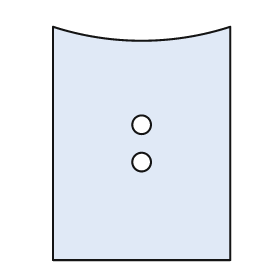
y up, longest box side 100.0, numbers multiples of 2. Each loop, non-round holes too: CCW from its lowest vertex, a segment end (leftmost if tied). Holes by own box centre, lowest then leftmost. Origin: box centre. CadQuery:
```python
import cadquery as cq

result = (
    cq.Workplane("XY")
    .moveTo(-38.0, -50.0)
    .lineTo(38.0, -50.0)
    .lineTo(38.0, 50.0)
    .threePointArc((0.0, 44.0), (-38.0, 50.0))
    .close()
    .moveTo(0.0, -8.0)
    .circle(4.0)
    .moveTo(0.0, 8.0)
    .circle(4.0)
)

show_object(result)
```